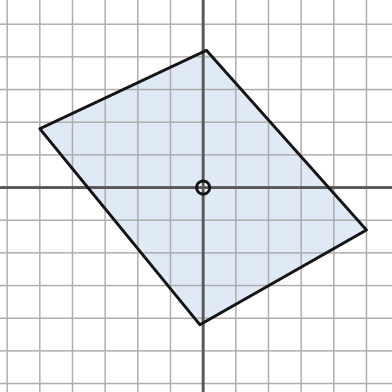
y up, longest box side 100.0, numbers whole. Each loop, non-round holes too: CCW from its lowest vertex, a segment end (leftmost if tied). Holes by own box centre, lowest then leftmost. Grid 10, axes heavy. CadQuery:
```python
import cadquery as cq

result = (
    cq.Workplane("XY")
    .moveTo(-1.0, -42.0)
    .lineTo(50.0, -13.0)
    .lineTo(1.0, 42.0)
    .lineTo(-50.0, 18.0)
    .close()
    .moveTo(0.0, 0.0)
    .circle(2.0)
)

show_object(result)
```